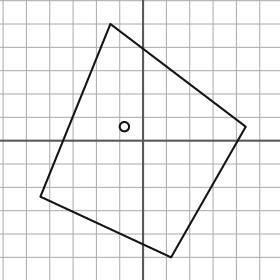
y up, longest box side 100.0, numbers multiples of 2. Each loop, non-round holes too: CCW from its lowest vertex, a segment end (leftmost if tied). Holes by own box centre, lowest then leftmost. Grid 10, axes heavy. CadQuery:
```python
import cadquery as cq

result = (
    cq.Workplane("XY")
    .moveTo(12.0, -50.0)
    .lineTo(44.0, 6.0)
    .lineTo(-14.0, 50.0)
    .lineTo(-44.0, -24.0)
    .close()
    .moveTo(-8.0, 6.0)
    .circle(2.0)
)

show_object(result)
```